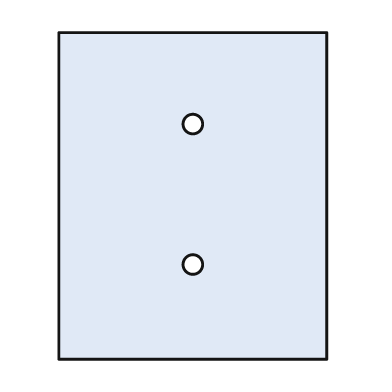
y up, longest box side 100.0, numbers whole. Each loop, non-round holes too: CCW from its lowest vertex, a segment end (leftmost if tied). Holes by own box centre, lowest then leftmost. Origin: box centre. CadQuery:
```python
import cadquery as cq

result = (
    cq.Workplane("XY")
    .moveTo(-41.0, -50.0)
    .lineTo(41.0, -50.0)
    .lineTo(41.0, 50.0)
    .lineTo(-41.0, 50.0)
    .close()
    .moveTo(0.0, -21.0)
    .circle(3.0)
    .moveTo(0.0, 22.0)
    .circle(3.0)
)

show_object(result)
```